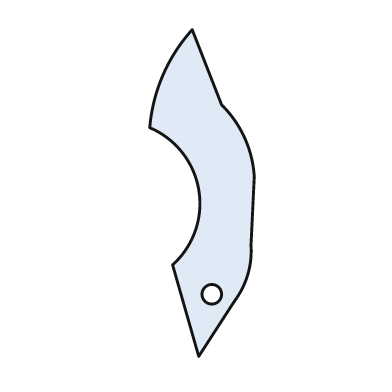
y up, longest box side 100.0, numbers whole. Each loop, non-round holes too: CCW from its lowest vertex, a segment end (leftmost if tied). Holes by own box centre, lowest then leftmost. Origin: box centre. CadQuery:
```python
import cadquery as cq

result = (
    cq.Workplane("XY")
    .moveTo(-1.0, -50.0)
    .lineTo(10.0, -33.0)
    .threePointArc((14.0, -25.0), (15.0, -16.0))
    .lineTo(16.0, 5.0)
    .threePointArc((13.0, 17.0), (6.0, 27.0))
    .lineTo(-3.0, 50.0)
    .threePointArc((-12.0, 36.0), (-16.0, 20.0))
    .threePointArc((-1.0, 1.0), (-9.0, -22.0))
    .close()
    .moveTo(3.0, -31.0)
    .circle(3.0)
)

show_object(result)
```